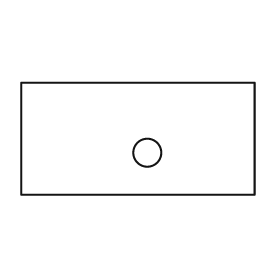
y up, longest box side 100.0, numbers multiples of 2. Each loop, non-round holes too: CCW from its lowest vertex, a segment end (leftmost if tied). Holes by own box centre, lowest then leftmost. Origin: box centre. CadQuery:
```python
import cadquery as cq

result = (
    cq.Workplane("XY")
    .moveTo(-50.0, -24.0)
    .lineTo(50.0, -24.0)
    .lineTo(50.0, 24.0)
    .lineTo(-50.0, 24.0)
    .close()
    .moveTo(4.0, -6.0)
    .circle(6.0)
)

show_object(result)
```